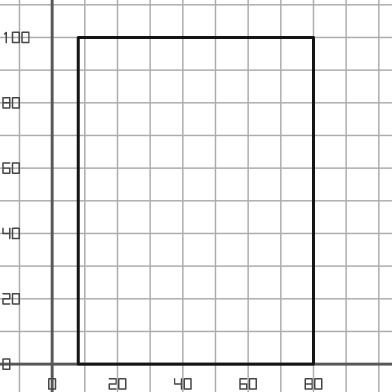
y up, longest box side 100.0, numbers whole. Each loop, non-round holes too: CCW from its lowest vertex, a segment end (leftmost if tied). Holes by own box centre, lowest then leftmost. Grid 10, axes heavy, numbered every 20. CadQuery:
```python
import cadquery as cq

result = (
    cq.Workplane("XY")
    .moveTo(8.0, 0.0)
    .lineTo(80.0, 0.0)
    .lineTo(80.0, 100.0)
    .lineTo(8.0, 100.0)
    .close()
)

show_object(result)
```